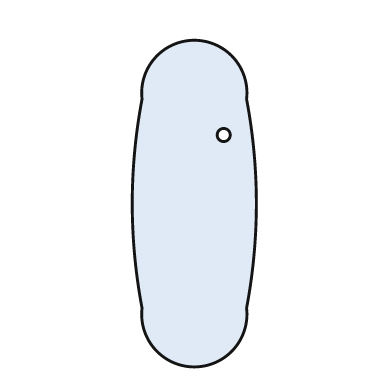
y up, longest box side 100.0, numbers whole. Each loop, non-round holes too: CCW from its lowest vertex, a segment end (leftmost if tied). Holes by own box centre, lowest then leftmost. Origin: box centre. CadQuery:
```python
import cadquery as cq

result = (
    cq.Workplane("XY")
    .moveTo(-16.0, -32.0)
    .threePointArc((0.0, -50.0), (16.0, -32.0))
    .threePointArc((19.0, 0.0), (16.0, 32.0))
    .threePointArc((0.0, 50.0), (-16.0, 32.0))
    .threePointArc((-19.0, 0.0), (-16.0, -32.0))
    .close()
    .moveTo(9.0, 21.0)
    .circle(2.0)
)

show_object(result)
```